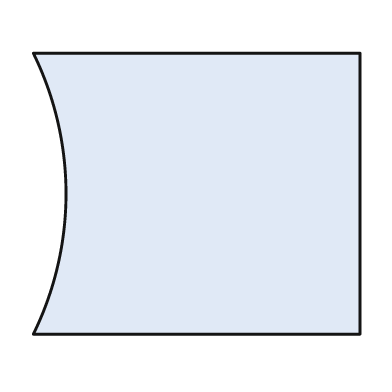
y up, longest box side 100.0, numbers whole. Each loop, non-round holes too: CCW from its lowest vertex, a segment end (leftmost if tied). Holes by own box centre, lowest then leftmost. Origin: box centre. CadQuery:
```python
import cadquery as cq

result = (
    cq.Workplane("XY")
    .moveTo(-50.0, -43.0)
    .lineTo(50.0, -43.0)
    .lineTo(50.0, 43.0)
    .lineTo(-50.0, 43.0)
    .threePointArc((-40.0, 0.0), (-50.0, -43.0))
    .close()
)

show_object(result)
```